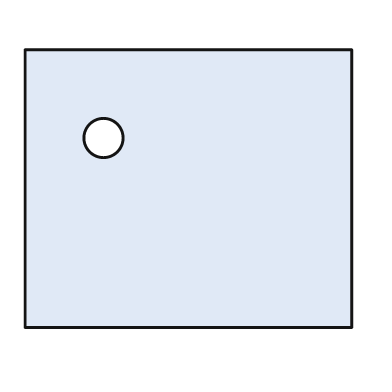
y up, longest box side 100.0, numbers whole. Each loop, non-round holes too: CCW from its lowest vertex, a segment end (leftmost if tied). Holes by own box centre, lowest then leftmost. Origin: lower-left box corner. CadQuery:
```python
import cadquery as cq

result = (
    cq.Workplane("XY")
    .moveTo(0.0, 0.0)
    .lineTo(100.0, 0.0)
    .lineTo(100.0, 85.0)
    .lineTo(0.0, 85.0)
    .close()
    .moveTo(24.0, 58.0)
    .circle(6.0)
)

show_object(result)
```